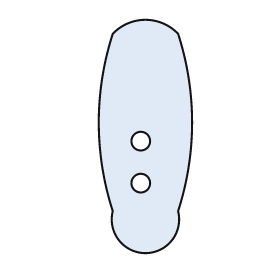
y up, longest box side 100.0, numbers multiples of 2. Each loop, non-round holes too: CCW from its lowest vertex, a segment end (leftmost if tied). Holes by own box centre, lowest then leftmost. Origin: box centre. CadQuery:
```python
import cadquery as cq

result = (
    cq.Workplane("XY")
    .moveTo(-14.0, -32.0)
    .threePointArc((0.0, -50.0), (14.0, -32.0))
    .threePointArc((20.0, 6.0), (14.0, 44.0))
    .threePointArc((0.0, 50.0), (-14.0, 44.0))
    .threePointArc((-20.0, 6.0), (-14.0, -32.0))
    .close()
    .moveTo(-2.0, -20.0)
    .circle(4.0)
    .moveTo(-2.0, -2.0)
    .circle(4.0)
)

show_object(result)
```